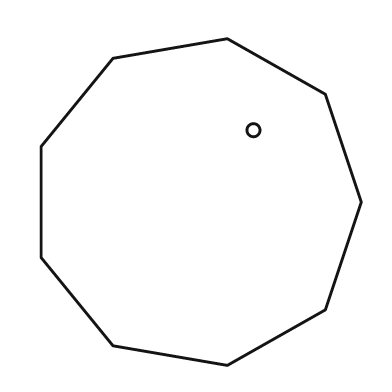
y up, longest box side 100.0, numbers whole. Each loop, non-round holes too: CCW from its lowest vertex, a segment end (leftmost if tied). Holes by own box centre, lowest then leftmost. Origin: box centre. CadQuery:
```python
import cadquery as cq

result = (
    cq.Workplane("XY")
    .moveTo(8.0, -50.0)
    .lineTo(38.0, -33.0)
    .lineTo(49.0, 0.0)
    .lineTo(38.0, 33.0)
    .lineTo(8.0, 50.0)
    .lineTo(-27.0, 44.0)
    .lineTo(-49.0, 17.0)
    .lineTo(-49.0, -17.0)
    .lineTo(-27.0, -44.0)
    .close()
    .moveTo(16.0, 22.0)
    .circle(2.0)
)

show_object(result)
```